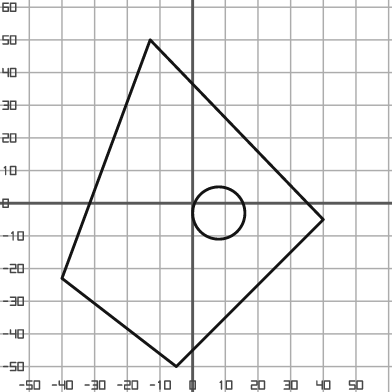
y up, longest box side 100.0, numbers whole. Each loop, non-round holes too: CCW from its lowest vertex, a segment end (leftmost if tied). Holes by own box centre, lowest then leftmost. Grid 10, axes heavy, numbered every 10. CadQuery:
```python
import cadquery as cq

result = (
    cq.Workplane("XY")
    .moveTo(-5.0, -50.0)
    .lineTo(40.0, -5.0)
    .lineTo(-13.0, 50.0)
    .lineTo(-40.0, -23.0)
    .close()
    .moveTo(8.0, -3.0)
    .circle(8.0)
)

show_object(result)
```